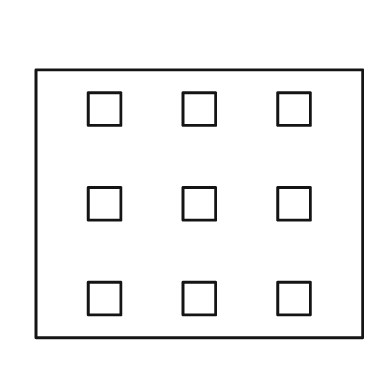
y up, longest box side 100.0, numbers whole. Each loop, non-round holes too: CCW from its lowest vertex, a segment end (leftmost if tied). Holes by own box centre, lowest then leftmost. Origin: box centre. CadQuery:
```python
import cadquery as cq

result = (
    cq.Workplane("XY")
    .moveTo(-50.0, -41.0)
    .lineTo(50.0, -41.0)
    .lineTo(50.0, 41.0)
    .lineTo(-50.0, 41.0)
    .close()
    .moveTo(-34.0, -34.0)
    .lineTo(-24.0, -34.0)
    .lineTo(-24.0, -24.0)
    .lineTo(-34.0, -24.0)
    .close()
    .moveTo(-5.0, -34.0)
    .lineTo(5.0, -34.0)
    .lineTo(5.0, -24.0)
    .lineTo(-5.0, -24.0)
    .close()
    .moveTo(24.0, -34.0)
    .lineTo(34.0, -34.0)
    .lineTo(34.0, -24.0)
    .lineTo(24.0, -24.0)
    .close()
    .moveTo(-34.0, -5.0)
    .lineTo(-24.0, -5.0)
    .lineTo(-24.0, 5.0)
    .lineTo(-34.0, 5.0)
    .close()
    .moveTo(-5.0, -5.0)
    .lineTo(5.0, -5.0)
    .lineTo(5.0, 5.0)
    .lineTo(-5.0, 5.0)
    .close()
    .moveTo(24.0, -5.0)
    .lineTo(34.0, -5.0)
    .lineTo(34.0, 5.0)
    .lineTo(24.0, 5.0)
    .close()
    .moveTo(-34.0, 24.0)
    .lineTo(-24.0, 24.0)
    .lineTo(-24.0, 34.0)
    .lineTo(-34.0, 34.0)
    .close()
    .moveTo(-5.0, 24.0)
    .lineTo(5.0, 24.0)
    .lineTo(5.0, 34.0)
    .lineTo(-5.0, 34.0)
    .close()
    .moveTo(24.0, 24.0)
    .lineTo(34.0, 24.0)
    .lineTo(34.0, 34.0)
    .lineTo(24.0, 34.0)
    .close()
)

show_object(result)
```